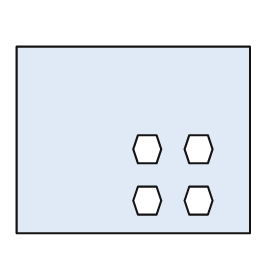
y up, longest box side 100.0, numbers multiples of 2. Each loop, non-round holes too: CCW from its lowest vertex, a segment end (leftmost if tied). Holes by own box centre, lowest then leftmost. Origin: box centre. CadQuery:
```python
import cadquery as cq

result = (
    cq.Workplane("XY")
    .moveTo(-50.0, -40.0)
    .lineTo(50.0, -40.0)
    .lineTo(50.0, 40.0)
    .lineTo(-50.0, 40.0)
    .close()
    .moveTo(2.0, -32.0)
    .lineTo(10.0, -32.0)
    .lineTo(12.0, -26.0)
    .lineTo(10.0, -20.0)
    .lineTo(2.0, -20.0)
    .lineTo(0.0, -26.0)
    .close()
    .moveTo(24.0, -32.0)
    .lineTo(32.0, -32.0)
    .lineTo(34.0, -26.0)
    .lineTo(32.0, -20.0)
    .lineTo(24.0, -20.0)
    .lineTo(22.0, -26.0)
    .close()
    .moveTo(2.0, -10.0)
    .lineTo(10.0, -10.0)
    .lineTo(12.0, -4.0)
    .lineTo(10.0, 2.0)
    .lineTo(2.0, 2.0)
    .lineTo(0.0, -4.0)
    .close()
    .moveTo(24.0, -10.0)
    .lineTo(32.0, -10.0)
    .lineTo(34.0, -4.0)
    .lineTo(32.0, 2.0)
    .lineTo(24.0, 2.0)
    .lineTo(22.0, -4.0)
    .close()
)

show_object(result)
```